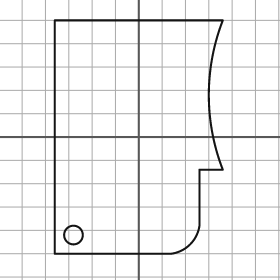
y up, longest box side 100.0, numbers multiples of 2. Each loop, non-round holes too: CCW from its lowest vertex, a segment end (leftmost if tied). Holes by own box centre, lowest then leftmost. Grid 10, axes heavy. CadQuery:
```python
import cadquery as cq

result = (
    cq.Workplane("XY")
    .moveTo(-36.0, -50.0)
    .lineTo(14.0, -50.0)
    .threePointArc((22.0, -46.0), (26.0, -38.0))
    .lineTo(26.0, -14.0)
    .lineTo(36.0, -14.0)
    .threePointArc((30.0, 18.0), (36.0, 50.0))
    .lineTo(-36.0, 50.0)
    .close()
    .moveTo(-28.0, -42.0)
    .circle(4.0)
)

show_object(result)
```